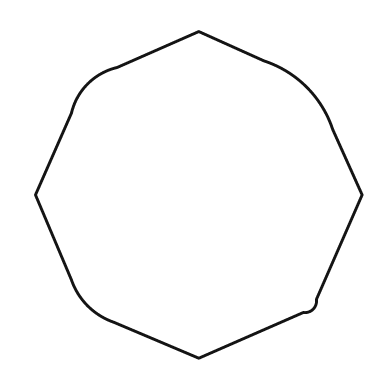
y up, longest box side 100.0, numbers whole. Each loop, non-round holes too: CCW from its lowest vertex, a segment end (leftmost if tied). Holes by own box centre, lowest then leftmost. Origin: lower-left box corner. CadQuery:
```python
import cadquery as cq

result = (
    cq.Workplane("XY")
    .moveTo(50.0, 0.0)
    .lineTo(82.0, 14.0)
    .threePointArc((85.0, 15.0), (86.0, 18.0))
    .lineTo(100.0, 50.0)
    .lineTo(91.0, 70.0)
    .threePointArc((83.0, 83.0), (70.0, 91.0))
    .lineTo(50.0, 100.0)
    .lineTo(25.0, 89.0)
    .threePointArc((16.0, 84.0), (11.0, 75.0))
    .lineTo(0.0, 50.0)
    .lineTo(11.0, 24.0)
    .threePointArc((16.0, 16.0), (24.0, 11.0))
    .close()
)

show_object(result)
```